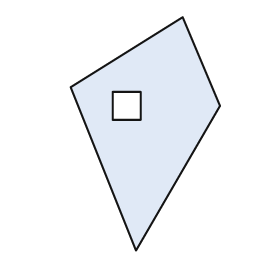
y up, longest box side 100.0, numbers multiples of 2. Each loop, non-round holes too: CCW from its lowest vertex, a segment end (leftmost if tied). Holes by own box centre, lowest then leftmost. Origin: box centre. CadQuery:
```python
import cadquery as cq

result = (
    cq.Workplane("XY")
    .moveTo(-4.0, -50.0)
    .lineTo(32.0, 12.0)
    .lineTo(16.0, 50.0)
    .lineTo(-32.0, 20.0)
    .close()
    .moveTo(-14.0, 6.0)
    .lineTo(-2.0, 6.0)
    .lineTo(-2.0, 18.0)
    .lineTo(-14.0, 18.0)
    .close()
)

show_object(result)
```